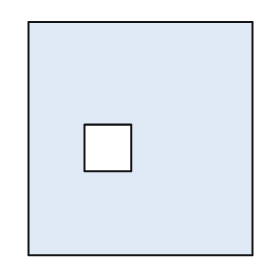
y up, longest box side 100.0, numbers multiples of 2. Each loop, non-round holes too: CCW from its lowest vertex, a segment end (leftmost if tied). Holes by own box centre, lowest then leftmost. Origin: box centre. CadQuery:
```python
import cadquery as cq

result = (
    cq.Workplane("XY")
    .moveTo(-48.0, -50.0)
    .lineTo(48.0, -50.0)
    .lineTo(48.0, 50.0)
    .lineTo(-48.0, 50.0)
    .close()
    .moveTo(-24.0, -14.0)
    .lineTo(-4.0, -14.0)
    .lineTo(-4.0, 6.0)
    .lineTo(-24.0, 6.0)
    .close()
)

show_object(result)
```